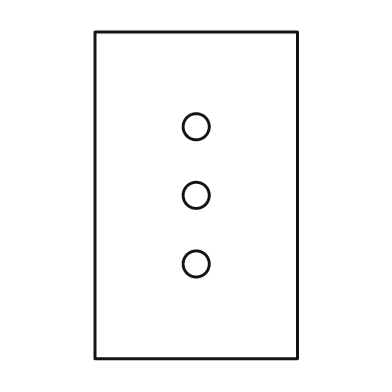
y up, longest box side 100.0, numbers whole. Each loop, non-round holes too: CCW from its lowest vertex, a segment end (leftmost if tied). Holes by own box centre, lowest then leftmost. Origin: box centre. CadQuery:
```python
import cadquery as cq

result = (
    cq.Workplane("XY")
    .moveTo(-31.0, -50.0)
    .lineTo(31.0, -50.0)
    .lineTo(31.0, 50.0)
    .lineTo(-31.0, 50.0)
    .close()
    .moveTo(0.0, -21.0)
    .circle(4.0)
    .moveTo(0.0, 0.0)
    .circle(4.0)
    .moveTo(0.0, 21.0)
    .circle(4.0)
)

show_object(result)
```